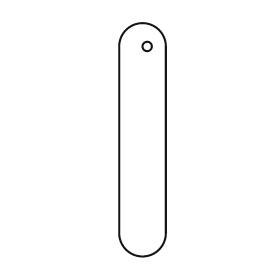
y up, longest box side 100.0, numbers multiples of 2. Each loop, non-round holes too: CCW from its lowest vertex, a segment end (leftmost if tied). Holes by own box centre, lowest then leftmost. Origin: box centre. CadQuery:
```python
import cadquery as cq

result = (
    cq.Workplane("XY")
    .moveTo(-10.0, -40.0)
    .threePointArc((0.0, -50.0), (10.0, -40.0))
    .lineTo(10.0, 40.0)
    .threePointArc((0.0, 50.0), (-10.0, 40.0))
    .close()
    .moveTo(2.0, 40.0)
    .circle(2.0)
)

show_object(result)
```